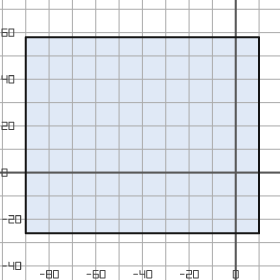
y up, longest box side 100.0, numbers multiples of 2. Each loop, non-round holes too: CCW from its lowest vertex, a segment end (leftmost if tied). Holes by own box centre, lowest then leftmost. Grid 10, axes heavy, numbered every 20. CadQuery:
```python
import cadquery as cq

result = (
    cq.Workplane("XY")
    .moveTo(-90.0, -26.0)
    .lineTo(10.0, -26.0)
    .lineTo(10.0, 58.0)
    .lineTo(-90.0, 58.0)
    .close()
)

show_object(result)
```